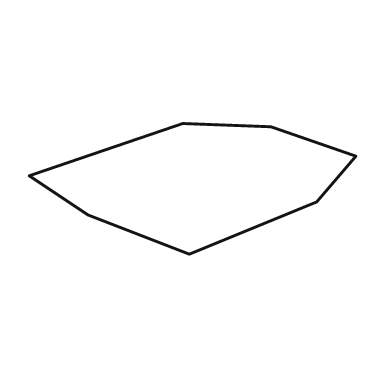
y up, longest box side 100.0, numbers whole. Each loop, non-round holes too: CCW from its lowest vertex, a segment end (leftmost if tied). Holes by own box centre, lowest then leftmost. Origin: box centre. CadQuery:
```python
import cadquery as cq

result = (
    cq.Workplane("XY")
    .moveTo(-1.0, -20.0)
    .lineTo(38.0, -4.0)
    .lineTo(50.0, 10.0)
    .lineTo(24.0, 19.0)
    .lineTo(-3.0, 20.0)
    .lineTo(-50.0, 4.0)
    .lineTo(-32.0, -8.0)
    .close()
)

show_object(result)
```